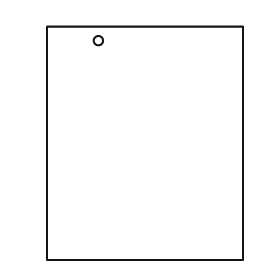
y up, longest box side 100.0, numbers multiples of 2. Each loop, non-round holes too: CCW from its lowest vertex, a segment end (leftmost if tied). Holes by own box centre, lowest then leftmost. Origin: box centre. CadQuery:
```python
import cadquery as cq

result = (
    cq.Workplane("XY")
    .moveTo(-42.0, -50.0)
    .lineTo(42.0, -50.0)
    .lineTo(42.0, 50.0)
    .lineTo(-42.0, 50.0)
    .close()
    .moveTo(-20.0, 44.0)
    .circle(2.0)
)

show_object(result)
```